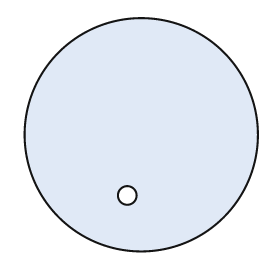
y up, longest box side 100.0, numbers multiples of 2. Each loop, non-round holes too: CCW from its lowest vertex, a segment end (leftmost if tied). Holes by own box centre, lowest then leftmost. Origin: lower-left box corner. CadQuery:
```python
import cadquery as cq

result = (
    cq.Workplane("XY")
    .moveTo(50.0, 50.0)
    .circle(50.0)
    .moveTo(44.0, 24.0)
    .circle(4.0)
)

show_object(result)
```